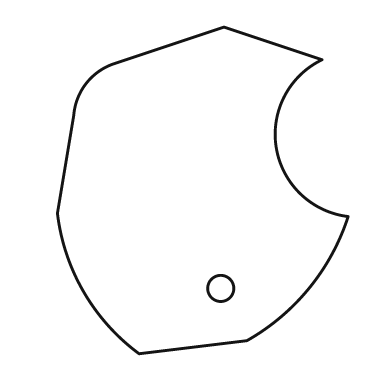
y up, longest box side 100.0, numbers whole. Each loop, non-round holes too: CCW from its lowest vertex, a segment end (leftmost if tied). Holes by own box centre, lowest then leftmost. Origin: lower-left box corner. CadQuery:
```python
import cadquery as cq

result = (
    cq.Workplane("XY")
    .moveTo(25.0, 0.0)
    .lineTo(58.0, 4.0)
    .threePointArc((77.0, 20.0), (89.0, 42.0))
    .threePointArc((67.0, 63.0), (81.0, 90.0))
    .lineTo(51.0, 100.0)
    .lineTo(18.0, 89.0)
    .threePointArc((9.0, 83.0), (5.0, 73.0))
    .lineTo(0.0, 43.0)
    .threePointArc((8.0, 19.0), (25.0, 0.0))
    .close()
    .moveTo(50.0, 20.0)
    .circle(4.0)
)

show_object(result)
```